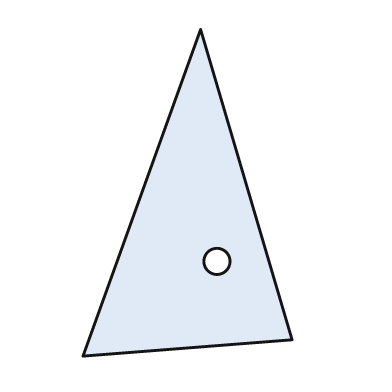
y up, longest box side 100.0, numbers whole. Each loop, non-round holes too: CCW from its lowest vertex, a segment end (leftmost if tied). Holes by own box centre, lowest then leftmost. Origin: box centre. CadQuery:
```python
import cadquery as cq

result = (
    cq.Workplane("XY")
    .moveTo(-32.0, -50.0)
    .lineTo(32.0, -45.0)
    .lineTo(4.0, 50.0)
    .close()
    .moveTo(9.0, -21.0)
    .circle(4.0)
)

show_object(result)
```